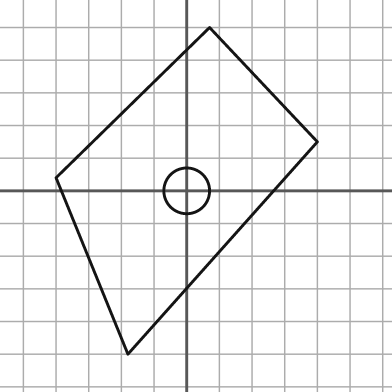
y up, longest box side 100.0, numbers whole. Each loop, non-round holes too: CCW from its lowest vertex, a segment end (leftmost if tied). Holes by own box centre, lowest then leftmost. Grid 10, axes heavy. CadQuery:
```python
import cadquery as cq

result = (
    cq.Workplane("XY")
    .moveTo(-18.0, -50.0)
    .lineTo(40.0, 15.0)
    .lineTo(7.0, 50.0)
    .lineTo(-40.0, 4.0)
    .close()
    .moveTo(0.0, 0.0)
    .circle(7.0)
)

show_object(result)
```